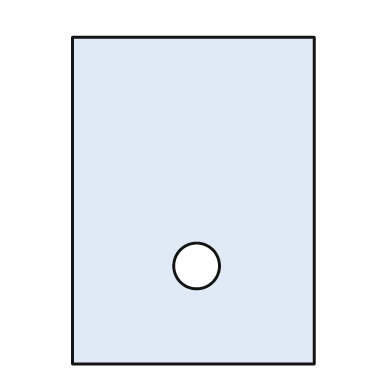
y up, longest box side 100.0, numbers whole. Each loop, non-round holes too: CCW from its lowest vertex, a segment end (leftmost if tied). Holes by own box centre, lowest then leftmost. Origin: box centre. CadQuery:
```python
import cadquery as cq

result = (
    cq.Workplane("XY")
    .moveTo(-37.0, -50.0)
    .lineTo(37.0, -50.0)
    .lineTo(37.0, 50.0)
    .lineTo(-37.0, 50.0)
    .close()
    .moveTo(1.0, -20.0)
    .circle(7.0)
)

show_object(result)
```